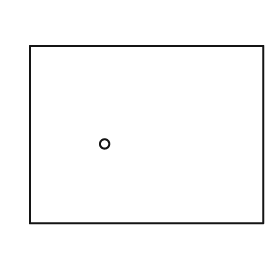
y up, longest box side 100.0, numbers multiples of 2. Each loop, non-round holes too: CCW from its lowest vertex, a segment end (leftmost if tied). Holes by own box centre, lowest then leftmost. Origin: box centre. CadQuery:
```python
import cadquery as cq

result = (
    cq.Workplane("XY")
    .moveTo(-50.0, -38.0)
    .lineTo(50.0, -38.0)
    .lineTo(50.0, 38.0)
    .lineTo(-50.0, 38.0)
    .close()
    .moveTo(-18.0, -4.0)
    .circle(2.0)
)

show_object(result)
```